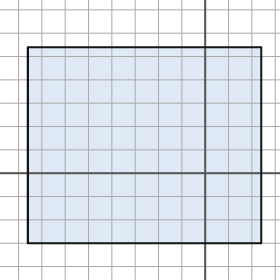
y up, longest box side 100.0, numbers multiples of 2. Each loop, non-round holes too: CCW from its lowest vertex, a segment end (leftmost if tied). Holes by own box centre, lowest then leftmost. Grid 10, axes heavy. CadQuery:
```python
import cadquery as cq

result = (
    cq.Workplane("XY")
    .moveTo(-76.0, -30.0)
    .lineTo(24.0, -30.0)
    .lineTo(24.0, 54.0)
    .lineTo(-76.0, 54.0)
    .close()
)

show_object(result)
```